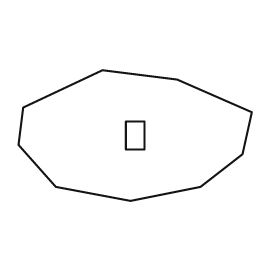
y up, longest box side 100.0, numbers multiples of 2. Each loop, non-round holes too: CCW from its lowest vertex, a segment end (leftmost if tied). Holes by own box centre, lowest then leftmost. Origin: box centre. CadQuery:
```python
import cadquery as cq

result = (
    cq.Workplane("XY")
    .moveTo(-2.0, -28.0)
    .lineTo(28.0, -22.0)
    .lineTo(46.0, -8.0)
    .lineTo(50.0, 10.0)
    .lineTo(18.0, 24.0)
    .lineTo(-14.0, 28.0)
    .lineTo(-48.0, 12.0)
    .lineTo(-50.0, -4.0)
    .lineTo(-34.0, -22.0)
    .close()
    .moveTo(-4.0, -6.0)
    .lineTo(4.0, -6.0)
    .lineTo(4.0, 6.0)
    .lineTo(-4.0, 6.0)
    .close()
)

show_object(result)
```